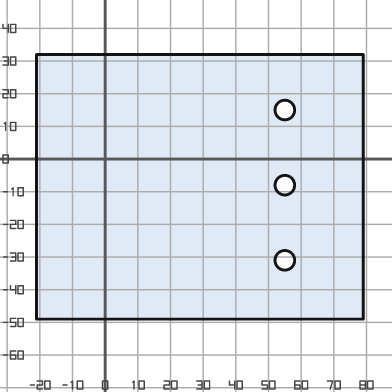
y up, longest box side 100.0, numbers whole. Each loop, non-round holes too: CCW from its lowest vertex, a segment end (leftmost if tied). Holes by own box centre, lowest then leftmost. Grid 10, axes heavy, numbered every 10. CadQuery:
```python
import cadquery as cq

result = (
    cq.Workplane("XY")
    .moveTo(-21.0, -49.0)
    .lineTo(79.0, -49.0)
    .lineTo(79.0, 32.0)
    .lineTo(-21.0, 32.0)
    .close()
    .moveTo(55.0, -31.0)
    .circle(3.0)
    .moveTo(55.0, -8.0)
    .circle(3.0)
    .moveTo(55.0, 15.0)
    .circle(3.0)
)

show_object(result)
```